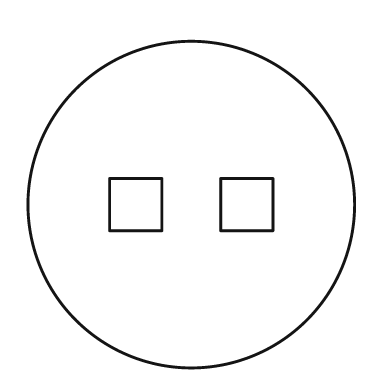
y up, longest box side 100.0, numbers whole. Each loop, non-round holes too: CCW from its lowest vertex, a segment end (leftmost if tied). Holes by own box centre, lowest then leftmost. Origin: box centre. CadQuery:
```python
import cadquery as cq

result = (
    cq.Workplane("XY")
    .moveTo(0.0, 0.0)
    .circle(50.0)
    .moveTo(-25.0, -8.0)
    .lineTo(-9.0, -8.0)
    .lineTo(-9.0, 8.0)
    .lineTo(-25.0, 8.0)
    .close()
    .moveTo(9.0, -8.0)
    .lineTo(25.0, -8.0)
    .lineTo(25.0, 8.0)
    .lineTo(9.0, 8.0)
    .close()
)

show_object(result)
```